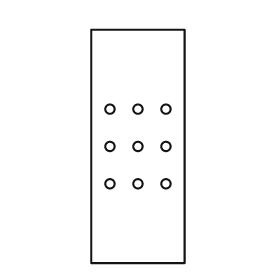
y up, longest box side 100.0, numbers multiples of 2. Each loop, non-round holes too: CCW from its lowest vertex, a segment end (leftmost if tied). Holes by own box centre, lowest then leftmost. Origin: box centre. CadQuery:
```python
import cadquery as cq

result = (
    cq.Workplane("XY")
    .moveTo(-20.0, -50.0)
    .lineTo(20.0, -50.0)
    .lineTo(20.0, 50.0)
    .lineTo(-20.0, 50.0)
    .close()
    .moveTo(-12.0, -16.0)
    .circle(2.0)
    .moveTo(0.0, -16.0)
    .circle(2.0)
    .moveTo(12.0, -16.0)
    .circle(2.0)
    .moveTo(-12.0, 0.0)
    .circle(2.0)
    .moveTo(0.0, 0.0)
    .circle(2.0)
    .moveTo(12.0, 0.0)
    .circle(2.0)
    .moveTo(-12.0, 16.0)
    .circle(2.0)
    .moveTo(0.0, 16.0)
    .circle(2.0)
    .moveTo(12.0, 16.0)
    .circle(2.0)
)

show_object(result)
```